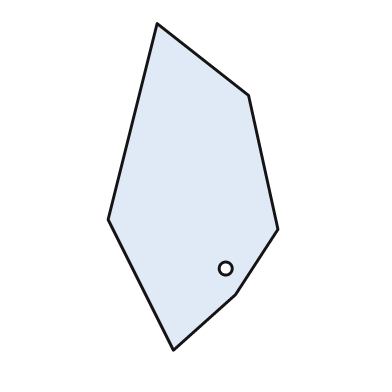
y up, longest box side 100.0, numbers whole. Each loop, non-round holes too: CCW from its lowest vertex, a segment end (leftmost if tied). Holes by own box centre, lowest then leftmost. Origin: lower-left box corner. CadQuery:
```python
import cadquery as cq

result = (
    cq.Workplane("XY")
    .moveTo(20.0, 0.0)
    .lineTo(39.0, 17.0)
    .lineTo(52.0, 37.0)
    .lineTo(43.0, 78.0)
    .lineTo(15.0, 100.0)
    .lineTo(0.0, 40.0)
    .close()
    .moveTo(36.0, 25.0)
    .circle(2.0)
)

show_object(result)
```